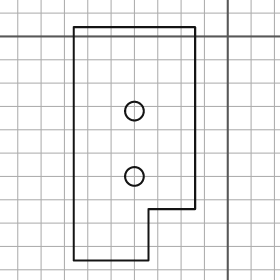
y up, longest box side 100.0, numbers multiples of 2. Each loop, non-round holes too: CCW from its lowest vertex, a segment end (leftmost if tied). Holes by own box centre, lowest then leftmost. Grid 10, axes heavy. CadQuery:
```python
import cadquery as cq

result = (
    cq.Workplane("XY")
    .moveTo(-66.0, -96.0)
    .lineTo(-34.0, -96.0)
    .lineTo(-34.0, -74.0)
    .lineTo(-14.0, -74.0)
    .lineTo(-14.0, 4.0)
    .lineTo(-66.0, 4.0)
    .close()
    .moveTo(-40.0, -60.0)
    .circle(4.0)
    .moveTo(-40.0, -32.0)
    .circle(4.0)
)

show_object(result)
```